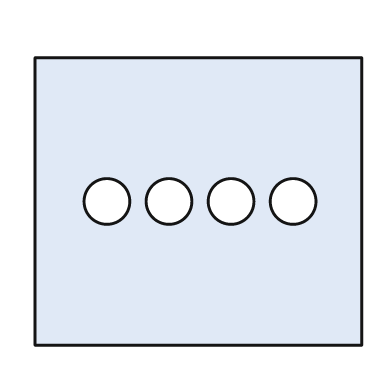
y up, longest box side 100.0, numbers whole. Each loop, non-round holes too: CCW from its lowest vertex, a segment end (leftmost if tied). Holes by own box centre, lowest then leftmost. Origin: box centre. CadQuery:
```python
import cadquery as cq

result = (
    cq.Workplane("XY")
    .moveTo(-50.0, -44.0)
    .lineTo(50.0, -44.0)
    .lineTo(50.0, 44.0)
    .lineTo(-50.0, 44.0)
    .close()
    .moveTo(-28.0, 0.0)
    .circle(7.0)
    .moveTo(-9.0, 0.0)
    .circle(7.0)
    .moveTo(10.0, 0.0)
    .circle(7.0)
    .moveTo(29.0, 0.0)
    .circle(7.0)
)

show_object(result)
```